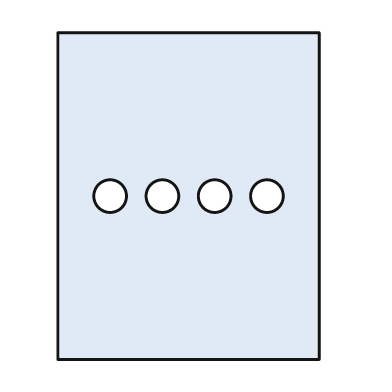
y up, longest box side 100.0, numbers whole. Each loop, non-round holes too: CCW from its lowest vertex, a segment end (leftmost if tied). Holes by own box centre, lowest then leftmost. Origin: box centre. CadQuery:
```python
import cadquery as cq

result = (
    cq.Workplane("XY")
    .moveTo(-40.0, -50.0)
    .lineTo(40.0, -50.0)
    .lineTo(40.0, 50.0)
    .lineTo(-40.0, 50.0)
    .close()
    .moveTo(-24.0, 0.0)
    .circle(5.0)
    .moveTo(-8.0, 0.0)
    .circle(5.0)
    .moveTo(8.0, 0.0)
    .circle(5.0)
    .moveTo(24.0, 0.0)
    .circle(5.0)
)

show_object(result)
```